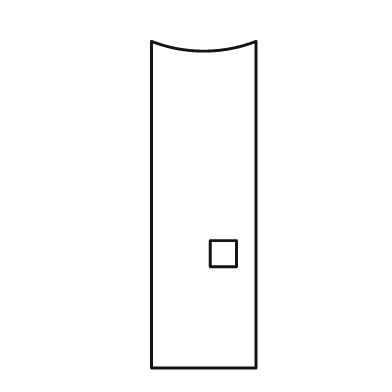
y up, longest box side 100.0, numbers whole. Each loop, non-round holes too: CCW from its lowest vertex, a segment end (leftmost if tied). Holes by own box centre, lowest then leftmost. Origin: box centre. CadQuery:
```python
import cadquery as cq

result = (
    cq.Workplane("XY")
    .moveTo(-16.0, -50.0)
    .lineTo(16.0, -50.0)
    .lineTo(16.0, 50.0)
    .threePointArc((0.0, 47.0), (-16.0, 50.0))
    .close()
    .moveTo(2.0, -19.0)
    .lineTo(10.0, -19.0)
    .lineTo(10.0, -11.0)
    .lineTo(2.0, -11.0)
    .close()
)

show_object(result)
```